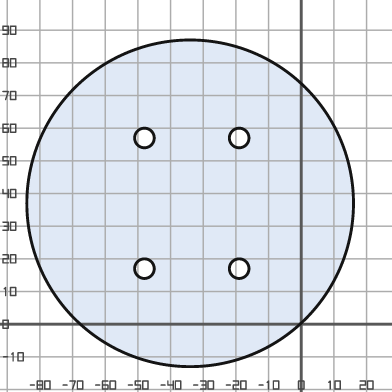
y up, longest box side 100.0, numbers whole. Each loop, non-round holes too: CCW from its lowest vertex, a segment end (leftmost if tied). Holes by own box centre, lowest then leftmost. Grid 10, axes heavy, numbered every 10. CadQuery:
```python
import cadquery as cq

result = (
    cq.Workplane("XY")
    .moveTo(-34.0, 37.0)
    .circle(50.0)
    .moveTo(-48.0, 17.0)
    .circle(3.0)
    .moveTo(-19.0, 17.0)
    .circle(3.0)
    .moveTo(-48.0, 57.0)
    .circle(3.0)
    .moveTo(-19.0, 57.0)
    .circle(3.0)
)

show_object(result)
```